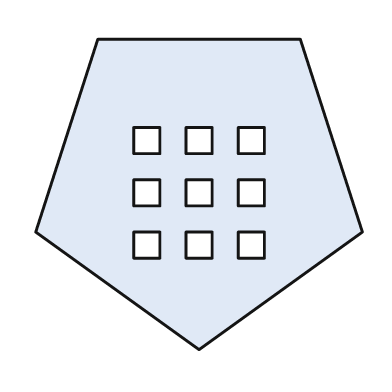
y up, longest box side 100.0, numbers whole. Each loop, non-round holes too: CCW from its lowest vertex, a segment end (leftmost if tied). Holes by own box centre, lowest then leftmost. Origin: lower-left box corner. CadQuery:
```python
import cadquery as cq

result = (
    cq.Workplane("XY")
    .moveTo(50.0, 0.0)
    .lineTo(100.0, 36.0)
    .lineTo(81.0, 95.0)
    .lineTo(19.0, 95.0)
    .lineTo(0.0, 36.0)
    .close()
    .moveTo(30.0, 28.0)
    .lineTo(38.0, 28.0)
    .lineTo(38.0, 36.0)
    .lineTo(30.0, 36.0)
    .close()
    .moveTo(46.0, 28.0)
    .lineTo(54.0, 28.0)
    .lineTo(54.0, 36.0)
    .lineTo(46.0, 36.0)
    .close()
    .moveTo(62.0, 28.0)
    .lineTo(70.0, 28.0)
    .lineTo(70.0, 36.0)
    .lineTo(62.0, 36.0)
    .close()
    .moveTo(30.0, 44.0)
    .lineTo(38.0, 44.0)
    .lineTo(38.0, 52.0)
    .lineTo(30.0, 52.0)
    .close()
    .moveTo(46.0, 44.0)
    .lineTo(54.0, 44.0)
    .lineTo(54.0, 52.0)
    .lineTo(46.0, 52.0)
    .close()
    .moveTo(62.0, 44.0)
    .lineTo(70.0, 44.0)
    .lineTo(70.0, 52.0)
    .lineTo(62.0, 52.0)
    .close()
    .moveTo(30.0, 60.0)
    .lineTo(38.0, 60.0)
    .lineTo(38.0, 68.0)
    .lineTo(30.0, 68.0)
    .close()
    .moveTo(46.0, 60.0)
    .lineTo(54.0, 60.0)
    .lineTo(54.0, 68.0)
    .lineTo(46.0, 68.0)
    .close()
    .moveTo(62.0, 60.0)
    .lineTo(70.0, 60.0)
    .lineTo(70.0, 68.0)
    .lineTo(62.0, 68.0)
    .close()
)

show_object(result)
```